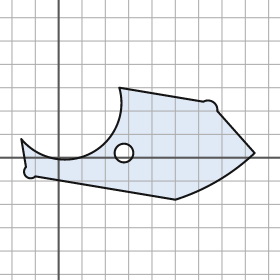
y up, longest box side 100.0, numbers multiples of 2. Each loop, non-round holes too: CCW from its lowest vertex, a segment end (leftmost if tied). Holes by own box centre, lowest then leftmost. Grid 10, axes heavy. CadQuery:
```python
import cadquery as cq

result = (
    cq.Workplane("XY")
    .moveTo(50.0, -18.0)
    .threePointArc((68.0, -10.0), (84.0, 2.0))
    .lineTo(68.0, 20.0)
    .threePointArc((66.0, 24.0), (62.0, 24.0))
    .lineTo(26.0, 30.0)
    .threePointArc((14.0, 2.0), (-16.0, 8.0))
    .lineTo(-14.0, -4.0)
    .threePointArc((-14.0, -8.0), (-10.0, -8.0))
    .close()
    .moveTo(28.0, 2.0)
    .circle(4.0)
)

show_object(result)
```